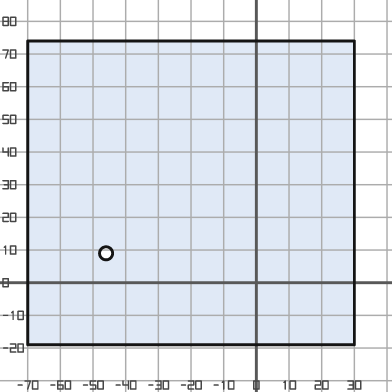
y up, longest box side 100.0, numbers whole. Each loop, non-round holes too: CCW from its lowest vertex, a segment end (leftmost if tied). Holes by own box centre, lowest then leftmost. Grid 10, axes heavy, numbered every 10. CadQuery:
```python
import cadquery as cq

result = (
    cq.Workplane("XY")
    .moveTo(-70.0, -19.0)
    .lineTo(30.0, -19.0)
    .lineTo(30.0, 74.0)
    .lineTo(-70.0, 74.0)
    .close()
    .moveTo(-46.0, 9.0)
    .circle(2.0)
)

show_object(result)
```